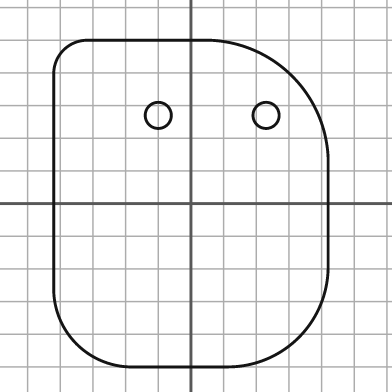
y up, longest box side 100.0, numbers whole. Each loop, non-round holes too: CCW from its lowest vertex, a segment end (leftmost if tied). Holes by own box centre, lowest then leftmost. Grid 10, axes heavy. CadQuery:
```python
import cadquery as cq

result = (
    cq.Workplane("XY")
    .moveTo(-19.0, -50.0)
    .lineTo(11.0, -50.0)
    .threePointArc((33.0, -41.0), (42.0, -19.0))
    .lineTo(42.0, 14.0)
    .threePointArc((31.0, 39.0), (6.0, 50.0))
    .lineTo(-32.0, 50.0)
    .threePointArc((-39.0, 47.0), (-42.0, 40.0))
    .lineTo(-42.0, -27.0)
    .threePointArc((-35.0, -43.0), (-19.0, -50.0))
    .close()
    .moveTo(-10.0, 27.0)
    .circle(4.0)
    .moveTo(23.0, 27.0)
    .circle(4.0)
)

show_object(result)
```